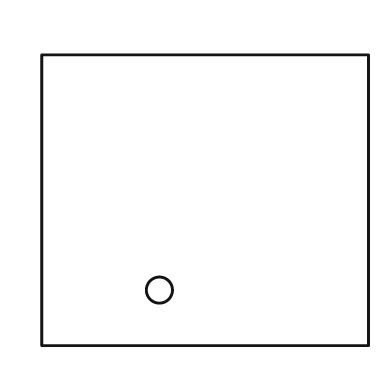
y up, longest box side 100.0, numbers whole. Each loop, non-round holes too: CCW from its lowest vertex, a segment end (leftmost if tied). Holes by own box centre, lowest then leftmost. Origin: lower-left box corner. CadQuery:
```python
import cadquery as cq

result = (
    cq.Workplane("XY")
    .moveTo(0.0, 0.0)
    .lineTo(100.0, 0.0)
    .lineTo(100.0, 89.0)
    .lineTo(0.0, 89.0)
    .close()
    .moveTo(36.0, 17.0)
    .circle(4.0)
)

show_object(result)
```